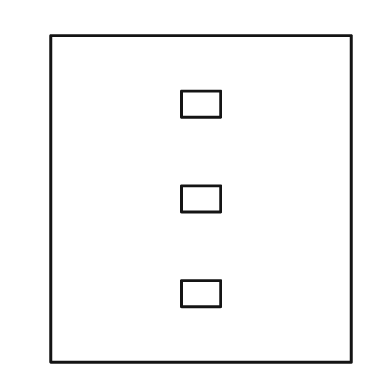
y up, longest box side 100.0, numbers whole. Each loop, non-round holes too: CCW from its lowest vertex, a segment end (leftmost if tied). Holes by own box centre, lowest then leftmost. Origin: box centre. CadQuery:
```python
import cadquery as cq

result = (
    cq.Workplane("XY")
    .moveTo(-46.0, -50.0)
    .lineTo(46.0, -50.0)
    .lineTo(46.0, 50.0)
    .lineTo(-46.0, 50.0)
    .close()
    .moveTo(-6.0, -33.0)
    .lineTo(6.0, -33.0)
    .lineTo(6.0, -25.0)
    .lineTo(-6.0, -25.0)
    .close()
    .moveTo(-6.0, -4.0)
    .lineTo(6.0, -4.0)
    .lineTo(6.0, 4.0)
    .lineTo(-6.0, 4.0)
    .close()
    .moveTo(-6.0, 25.0)
    .lineTo(6.0, 25.0)
    .lineTo(6.0, 33.0)
    .lineTo(-6.0, 33.0)
    .close()
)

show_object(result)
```